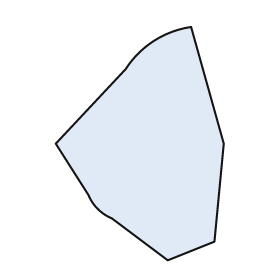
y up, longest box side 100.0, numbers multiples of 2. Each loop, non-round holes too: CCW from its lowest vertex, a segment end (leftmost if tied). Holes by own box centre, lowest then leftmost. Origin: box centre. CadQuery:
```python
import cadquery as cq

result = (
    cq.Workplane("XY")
    .moveTo(12.0, -50.0)
    .lineTo(32.0, -42.0)
    .lineTo(36.0, 0.0)
    .lineTo(22.0, 50.0)
    .threePointArc((6.0, 44.0), (-6.0, 32.0))
    .lineTo(-36.0, 0.0)
    .lineTo(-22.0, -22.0)
    .threePointArc((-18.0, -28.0), (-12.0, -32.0))
    .close()
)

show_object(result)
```